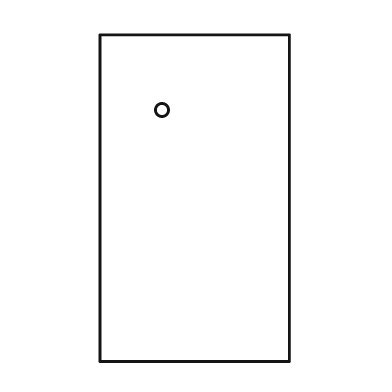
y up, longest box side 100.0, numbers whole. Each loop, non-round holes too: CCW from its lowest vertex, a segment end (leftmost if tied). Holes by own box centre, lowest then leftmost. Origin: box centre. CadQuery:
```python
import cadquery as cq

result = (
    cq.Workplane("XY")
    .moveTo(-29.0, -50.0)
    .lineTo(29.0, -50.0)
    .lineTo(29.0, 50.0)
    .lineTo(-29.0, 50.0)
    .close()
    .moveTo(-10.0, 27.0)
    .circle(2.0)
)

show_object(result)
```